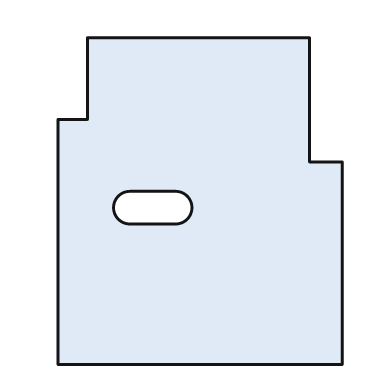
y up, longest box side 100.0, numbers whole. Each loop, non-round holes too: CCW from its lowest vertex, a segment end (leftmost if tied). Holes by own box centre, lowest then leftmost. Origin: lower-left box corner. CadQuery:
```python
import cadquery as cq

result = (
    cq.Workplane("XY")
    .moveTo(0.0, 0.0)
    .lineTo(87.0, 0.0)
    .lineTo(87.0, 62.0)
    .lineTo(77.0, 62.0)
    .lineTo(77.0, 100.0)
    .lineTo(9.0, 100.0)
    .lineTo(9.0, 75.0)
    .lineTo(0.0, 75.0)
    .close()
    .moveTo(22.0, 43.0)
    .lineTo(36.0, 43.0)
    .threePointArc((41.0, 48.0), (36.0, 53.0))
    .lineTo(22.0, 53.0)
    .threePointArc((17.0, 48.0), (22.0, 43.0))
    .close()
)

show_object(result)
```